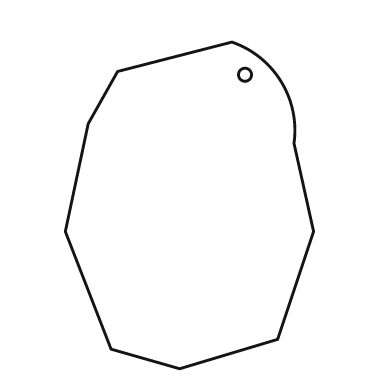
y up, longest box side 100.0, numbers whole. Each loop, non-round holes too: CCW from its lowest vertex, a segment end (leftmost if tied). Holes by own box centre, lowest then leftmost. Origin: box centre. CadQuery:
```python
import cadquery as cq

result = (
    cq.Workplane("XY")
    .moveTo(-3.0, -50.0)
    .lineTo(27.0, -41.0)
    .lineTo(38.0, -8.0)
    .lineTo(32.0, 19.0)
    .threePointArc((28.0, 38.0), (13.0, 50.0))
    .lineTo(-22.0, 41.0)
    .lineTo(-31.0, 25.0)
    .lineTo(-38.0, -8.0)
    .lineTo(-24.0, -44.0)
    .close()
    .moveTo(17.0, 40.0)
    .circle(2.0)
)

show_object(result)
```